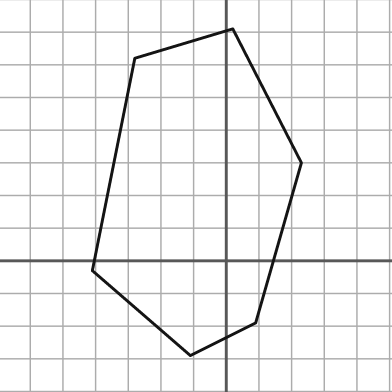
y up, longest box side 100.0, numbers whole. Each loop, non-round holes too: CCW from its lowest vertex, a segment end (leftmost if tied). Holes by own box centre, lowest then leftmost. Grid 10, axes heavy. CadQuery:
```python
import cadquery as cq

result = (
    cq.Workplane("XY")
    .moveTo(-11.0, -29.0)
    .lineTo(9.0, -19.0)
    .lineTo(23.0, 30.0)
    .lineTo(2.0, 71.0)
    .lineTo(-28.0, 62.0)
    .lineTo(-41.0, -3.0)
    .close()
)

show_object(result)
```